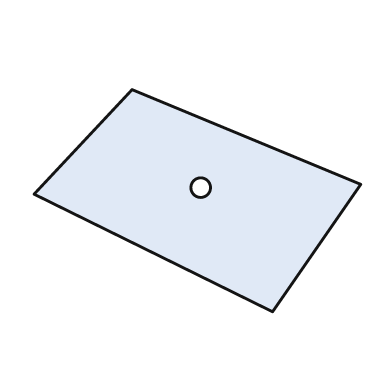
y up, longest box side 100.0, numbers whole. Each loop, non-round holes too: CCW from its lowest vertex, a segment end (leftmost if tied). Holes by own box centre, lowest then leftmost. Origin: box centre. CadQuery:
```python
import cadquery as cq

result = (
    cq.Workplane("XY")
    .moveTo(23.0, -34.0)
    .lineTo(50.0, 5.0)
    .lineTo(-20.0, 34.0)
    .lineTo(-50.0, 2.0)
    .close()
    .moveTo(1.0, 4.0)
    .circle(3.0)
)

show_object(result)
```